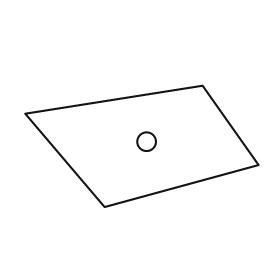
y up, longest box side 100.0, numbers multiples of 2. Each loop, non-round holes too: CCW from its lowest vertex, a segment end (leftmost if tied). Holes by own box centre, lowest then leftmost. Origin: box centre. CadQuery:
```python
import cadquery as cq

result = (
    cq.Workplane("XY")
    .moveTo(-16.0, -26.0)
    .lineTo(50.0, -8.0)
    .lineTo(26.0, 26.0)
    .lineTo(-50.0, 14.0)
    .close()
    .moveTo(2.0, 2.0)
    .circle(4.0)
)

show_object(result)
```